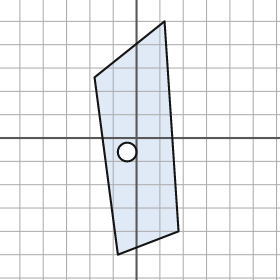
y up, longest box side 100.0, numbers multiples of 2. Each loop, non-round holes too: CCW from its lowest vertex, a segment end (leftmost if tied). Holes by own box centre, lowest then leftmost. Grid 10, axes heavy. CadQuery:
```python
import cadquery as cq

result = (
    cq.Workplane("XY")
    .moveTo(-8.0, -50.0)
    .lineTo(18.0, -40.0)
    .lineTo(12.0, 50.0)
    .lineTo(-18.0, 26.0)
    .close()
    .moveTo(-4.0, -6.0)
    .circle(4.0)
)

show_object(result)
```